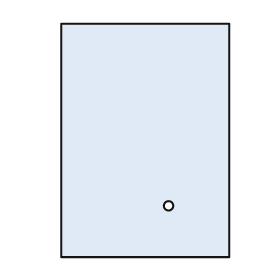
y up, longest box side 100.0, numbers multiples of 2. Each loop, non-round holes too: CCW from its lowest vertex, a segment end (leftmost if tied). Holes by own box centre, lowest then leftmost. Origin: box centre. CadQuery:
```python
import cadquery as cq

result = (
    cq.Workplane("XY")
    .moveTo(-36.0, -50.0)
    .lineTo(36.0, -50.0)
    .lineTo(36.0, 50.0)
    .lineTo(-36.0, 50.0)
    .close()
    .moveTo(10.0, -28.0)
    .circle(2.0)
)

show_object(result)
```